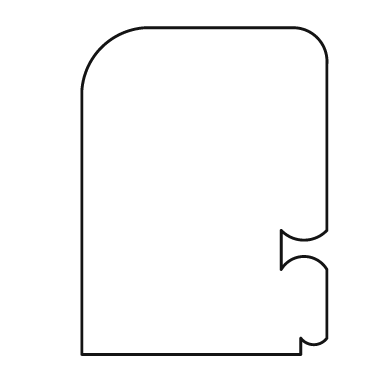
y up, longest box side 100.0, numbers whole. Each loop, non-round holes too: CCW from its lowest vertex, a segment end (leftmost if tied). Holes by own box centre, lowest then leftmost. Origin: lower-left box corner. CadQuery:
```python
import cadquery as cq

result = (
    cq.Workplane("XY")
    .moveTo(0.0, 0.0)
    .lineTo(67.0, 0.0)
    .lineTo(67.0, 5.0)
    .threePointArc((71.0, 3.0), (75.0, 5.0))
    .lineTo(75.0, 26.0)
    .threePointArc((68.0, 30.0), (61.0, 26.0))
    .lineTo(61.0, 38.0)
    .threePointArc((68.0, 35.0), (75.0, 38.0))
    .lineTo(75.0, 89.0)
    .threePointArc((72.0, 97.0), (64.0, 100.0))
    .lineTo(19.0, 100.0)
    .threePointArc((6.0, 94.0), (0.0, 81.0))
    .close()
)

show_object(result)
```